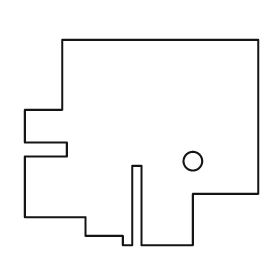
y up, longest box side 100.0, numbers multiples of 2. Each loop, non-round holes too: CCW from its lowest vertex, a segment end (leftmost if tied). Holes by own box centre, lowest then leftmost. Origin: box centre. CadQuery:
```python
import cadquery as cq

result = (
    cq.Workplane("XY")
    .moveTo(-8.0, -44.0)
    .lineTo(-4.0, -44.0)
    .lineTo(-4.0, -10.0)
    .lineTo(0.0, -10.0)
    .lineTo(0.0, -44.0)
    .lineTo(22.0, -44.0)
    .lineTo(22.0, -22.0)
    .lineTo(50.0, -22.0)
    .lineTo(50.0, 44.0)
    .lineTo(-34.0, 44.0)
    .lineTo(-34.0, 14.0)
    .lineTo(-50.0, 14.0)
    .lineTo(-50.0, 0.0)
    .lineTo(-32.0, 0.0)
    .lineTo(-32.0, -6.0)
    .lineTo(-50.0, -6.0)
    .lineTo(-50.0, -32.0)
    .lineTo(-24.0, -32.0)
    .lineTo(-24.0, -40.0)
    .lineTo(-8.0, -40.0)
    .close()
    .moveTo(22.0, -8.0)
    .circle(4.0)
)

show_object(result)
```